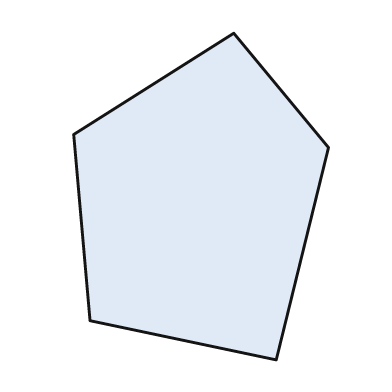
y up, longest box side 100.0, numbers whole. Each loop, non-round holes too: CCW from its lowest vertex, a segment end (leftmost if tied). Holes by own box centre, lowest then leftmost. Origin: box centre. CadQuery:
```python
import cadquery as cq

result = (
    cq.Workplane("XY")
    .moveTo(23.0, -50.0)
    .lineTo(39.0, 15.0)
    .lineTo(10.0, 50.0)
    .lineTo(-39.0, 19.0)
    .lineTo(-34.0, -38.0)
    .close()
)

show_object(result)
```